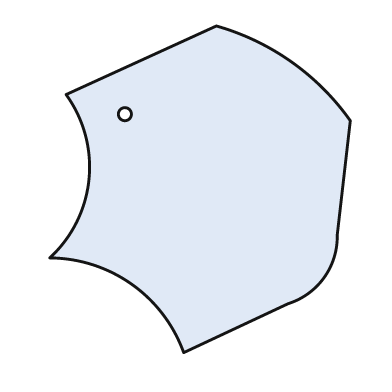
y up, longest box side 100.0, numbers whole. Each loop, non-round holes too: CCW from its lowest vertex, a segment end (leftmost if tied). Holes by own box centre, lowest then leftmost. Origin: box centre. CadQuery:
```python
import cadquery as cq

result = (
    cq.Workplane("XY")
    .moveTo(-5.0, -50.0)
    .lineTo(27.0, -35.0)
    .threePointArc((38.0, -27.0), (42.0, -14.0))
    .lineTo(46.0, 21.0)
    .threePointArc((28.0, 39.0), (5.0, 50.0))
    .lineTo(-41.0, 29.0)
    .threePointArc((-34.0, 3.0), (-46.0, -21.0))
    .threePointArc((-21.0, -29.0), (-5.0, -50.0))
    .close()
    .moveTo(-23.0, 23.0)
    .circle(2.0)
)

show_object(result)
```